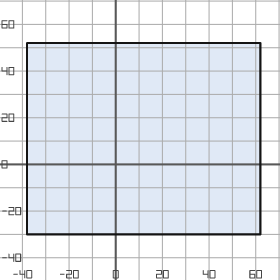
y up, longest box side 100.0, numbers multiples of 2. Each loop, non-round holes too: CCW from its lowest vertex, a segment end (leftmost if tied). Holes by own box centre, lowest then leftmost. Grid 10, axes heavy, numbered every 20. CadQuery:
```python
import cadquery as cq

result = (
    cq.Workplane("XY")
    .moveTo(-38.0, -30.0)
    .lineTo(62.0, -30.0)
    .lineTo(62.0, 52.0)
    .lineTo(-38.0, 52.0)
    .close()
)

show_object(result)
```